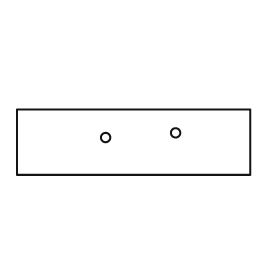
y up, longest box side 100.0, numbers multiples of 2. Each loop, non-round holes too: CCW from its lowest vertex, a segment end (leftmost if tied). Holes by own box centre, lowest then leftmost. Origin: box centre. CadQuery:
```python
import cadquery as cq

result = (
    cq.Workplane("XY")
    .moveTo(-50.0, -14.0)
    .lineTo(50.0, -14.0)
    .lineTo(50.0, 14.0)
    .lineTo(-50.0, 14.0)
    .close()
    .moveTo(-12.0, 2.0)
    .circle(2.0)
    .moveTo(18.0, 4.0)
    .circle(2.0)
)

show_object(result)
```